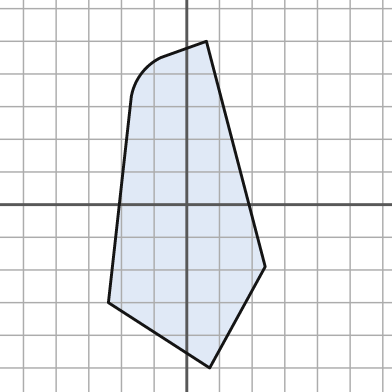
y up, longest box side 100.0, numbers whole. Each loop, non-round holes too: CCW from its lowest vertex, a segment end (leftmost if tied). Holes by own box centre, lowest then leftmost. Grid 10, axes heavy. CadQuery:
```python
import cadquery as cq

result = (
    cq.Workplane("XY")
    .moveTo(7.0, -50.0)
    .lineTo(24.0, -19.0)
    .lineTo(6.0, 50.0)
    .lineTo(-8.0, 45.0)
    .threePointArc((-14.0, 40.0), (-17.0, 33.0))
    .lineTo(-24.0, -30.0)
    .close()
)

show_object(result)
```